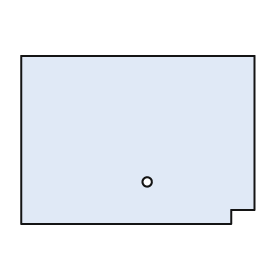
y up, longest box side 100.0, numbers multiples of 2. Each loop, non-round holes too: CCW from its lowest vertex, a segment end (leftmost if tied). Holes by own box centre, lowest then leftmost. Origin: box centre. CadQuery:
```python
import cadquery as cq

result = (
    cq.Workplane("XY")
    .moveTo(-50.0, -36.0)
    .lineTo(40.0, -36.0)
    .lineTo(40.0, -30.0)
    .lineTo(50.0, -30.0)
    .lineTo(50.0, 36.0)
    .lineTo(-50.0, 36.0)
    .close()
    .moveTo(4.0, -18.0)
    .circle(2.0)
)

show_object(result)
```